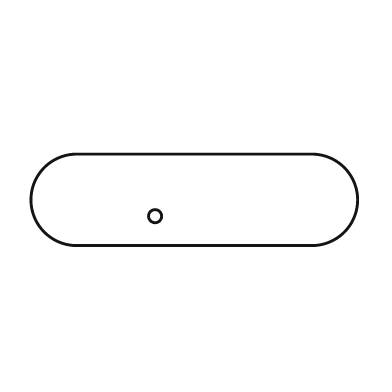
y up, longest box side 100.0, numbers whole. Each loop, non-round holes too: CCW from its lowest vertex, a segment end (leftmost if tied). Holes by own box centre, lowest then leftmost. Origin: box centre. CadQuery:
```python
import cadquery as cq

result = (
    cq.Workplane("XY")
    .moveTo(-36.0, -14.0)
    .lineTo(36.0, -14.0)
    .threePointArc((50.0, 0.0), (36.0, 14.0))
    .lineTo(-36.0, 14.0)
    .threePointArc((-50.0, 0.0), (-36.0, -14.0))
    .close()
    .moveTo(-12.0, -5.0)
    .circle(2.0)
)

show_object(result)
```